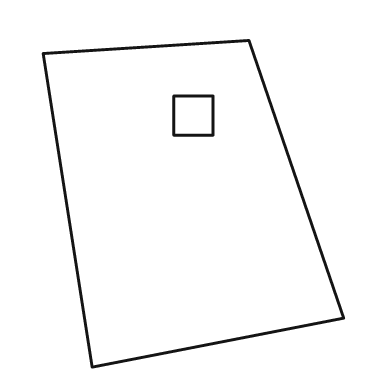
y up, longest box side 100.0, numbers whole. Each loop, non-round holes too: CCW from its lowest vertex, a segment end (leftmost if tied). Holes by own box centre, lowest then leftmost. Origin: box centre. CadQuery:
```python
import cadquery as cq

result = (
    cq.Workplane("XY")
    .moveTo(-31.0, -50.0)
    .lineTo(46.0, -35.0)
    .lineTo(17.0, 50.0)
    .lineTo(-46.0, 46.0)
    .close()
    .moveTo(-6.0, 21.0)
    .lineTo(6.0, 21.0)
    .lineTo(6.0, 33.0)
    .lineTo(-6.0, 33.0)
    .close()
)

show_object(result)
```